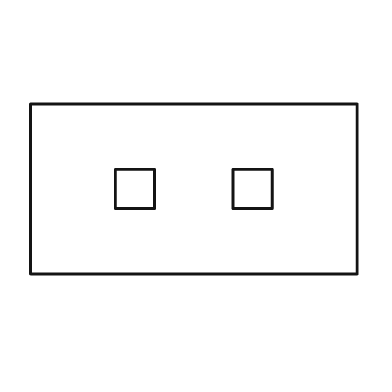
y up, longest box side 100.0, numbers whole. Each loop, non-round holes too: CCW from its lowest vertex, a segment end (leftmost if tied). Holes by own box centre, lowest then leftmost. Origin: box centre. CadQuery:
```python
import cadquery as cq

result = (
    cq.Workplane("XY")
    .moveTo(-50.0, -26.0)
    .lineTo(50.0, -26.0)
    .lineTo(50.0, 26.0)
    .lineTo(-50.0, 26.0)
    .close()
    .moveTo(-24.0, -6.0)
    .lineTo(-12.0, -6.0)
    .lineTo(-12.0, 6.0)
    .lineTo(-24.0, 6.0)
    .close()
    .moveTo(12.0, -6.0)
    .lineTo(24.0, -6.0)
    .lineTo(24.0, 6.0)
    .lineTo(12.0, 6.0)
    .close()
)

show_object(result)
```